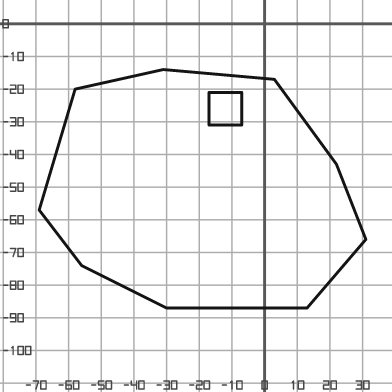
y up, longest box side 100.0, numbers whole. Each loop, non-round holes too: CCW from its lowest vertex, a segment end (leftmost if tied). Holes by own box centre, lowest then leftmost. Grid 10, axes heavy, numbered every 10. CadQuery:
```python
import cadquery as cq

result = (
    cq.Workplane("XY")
    .moveTo(-30.0, -87.0)
    .lineTo(13.0, -87.0)
    .lineTo(31.0, -66.0)
    .lineTo(22.0, -43.0)
    .lineTo(3.0, -17.0)
    .lineTo(-31.0, -14.0)
    .lineTo(-58.0, -20.0)
    .lineTo(-69.0, -57.0)
    .lineTo(-56.0, -74.0)
    .close()
    .moveTo(-17.0, -31.0)
    .lineTo(-7.0, -31.0)
    .lineTo(-7.0, -21.0)
    .lineTo(-17.0, -21.0)
    .close()
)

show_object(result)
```